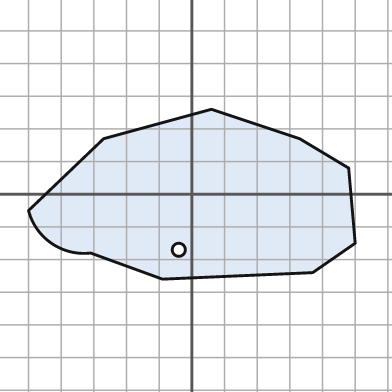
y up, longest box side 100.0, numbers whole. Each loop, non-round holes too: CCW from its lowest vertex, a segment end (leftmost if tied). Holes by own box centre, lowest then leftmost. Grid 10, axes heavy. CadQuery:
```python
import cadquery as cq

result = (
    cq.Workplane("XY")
    .moveTo(-9.0, -26.0)
    .lineTo(37.0, -24.0)
    .lineTo(50.0, -15.0)
    .lineTo(48.0, 8.0)
    .lineTo(33.0, 17.0)
    .lineTo(6.0, 26.0)
    .lineTo(-27.0, 17.0)
    .lineTo(-50.0, -5.0)
    .threePointArc((-43.0, -15.0), (-31.0, -18.0))
    .close()
    .moveTo(-4.0, -17.0)
    .circle(2.0)
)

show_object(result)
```